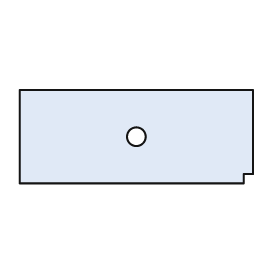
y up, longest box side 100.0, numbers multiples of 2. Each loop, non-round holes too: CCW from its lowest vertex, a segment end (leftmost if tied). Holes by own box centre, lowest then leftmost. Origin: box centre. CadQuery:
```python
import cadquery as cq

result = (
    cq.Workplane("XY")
    .moveTo(-50.0, -20.0)
    .lineTo(46.0, -20.0)
    .lineTo(46.0, -16.0)
    .lineTo(50.0, -16.0)
    .lineTo(50.0, 20.0)
    .lineTo(-50.0, 20.0)
    .close()
    .moveTo(0.0, 0.0)
    .circle(4.0)
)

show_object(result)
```